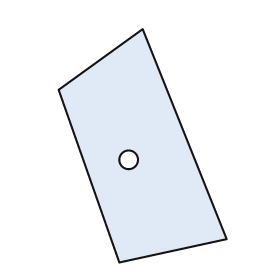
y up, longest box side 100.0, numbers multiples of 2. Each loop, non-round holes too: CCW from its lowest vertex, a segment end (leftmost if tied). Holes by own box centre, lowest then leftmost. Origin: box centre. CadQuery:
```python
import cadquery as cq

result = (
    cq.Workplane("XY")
    .moveTo(-10.0, -50.0)
    .lineTo(36.0, -40.0)
    .lineTo(0.0, 50.0)
    .lineTo(-36.0, 24.0)
    .close()
    .moveTo(-6.0, -6.0)
    .circle(4.0)
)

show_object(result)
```